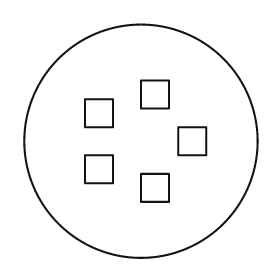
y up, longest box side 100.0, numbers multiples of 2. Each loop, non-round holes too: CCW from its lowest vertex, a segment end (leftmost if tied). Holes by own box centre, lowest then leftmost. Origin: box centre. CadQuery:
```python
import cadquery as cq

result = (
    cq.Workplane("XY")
    .moveTo(0.0, 0.0)
    .circle(50.0)
    .moveTo(0.0, -26.0)
    .lineTo(12.0, -26.0)
    .lineTo(12.0, -14.0)
    .lineTo(0.0, -14.0)
    .close()
    .moveTo(-24.0, -18.0)
    .lineTo(-12.0, -18.0)
    .lineTo(-12.0, -6.0)
    .lineTo(-24.0, -6.0)
    .close()
    .moveTo(16.0, -6.0)
    .lineTo(28.0, -6.0)
    .lineTo(28.0, 6.0)
    .lineTo(16.0, 6.0)
    .close()
    .moveTo(-24.0, 6.0)
    .lineTo(-12.0, 6.0)
    .lineTo(-12.0, 18.0)
    .lineTo(-24.0, 18.0)
    .close()
    .moveTo(0.0, 14.0)
    .lineTo(12.0, 14.0)
    .lineTo(12.0, 26.0)
    .lineTo(0.0, 26.0)
    .close()
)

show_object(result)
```